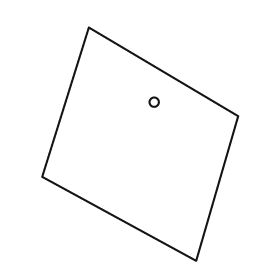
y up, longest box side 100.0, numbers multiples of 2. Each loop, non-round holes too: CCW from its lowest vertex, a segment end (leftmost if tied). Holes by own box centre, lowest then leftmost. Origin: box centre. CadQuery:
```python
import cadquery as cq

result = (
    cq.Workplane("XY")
    .moveTo(24.0, -50.0)
    .lineTo(42.0, 12.0)
    .lineTo(-22.0, 50.0)
    .lineTo(-42.0, -14.0)
    .close()
    .moveTo(6.0, 18.0)
    .circle(2.0)
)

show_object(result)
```